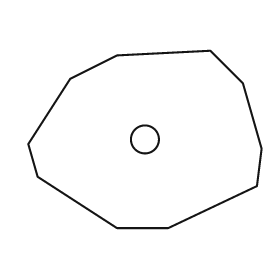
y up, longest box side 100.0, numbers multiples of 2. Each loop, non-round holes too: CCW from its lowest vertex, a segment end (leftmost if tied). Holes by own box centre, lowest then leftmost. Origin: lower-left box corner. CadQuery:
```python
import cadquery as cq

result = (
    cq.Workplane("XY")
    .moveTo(38.0, 0.0)
    .lineTo(60.0, 0.0)
    .lineTo(98.0, 18.0)
    .lineTo(100.0, 34.0)
    .lineTo(92.0, 62.0)
    .lineTo(78.0, 76.0)
    .lineTo(38.0, 74.0)
    .lineTo(18.0, 64.0)
    .lineTo(0.0, 36.0)
    .lineTo(4.0, 22.0)
    .close()
    .moveTo(50.0, 38.0)
    .circle(6.0)
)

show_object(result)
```